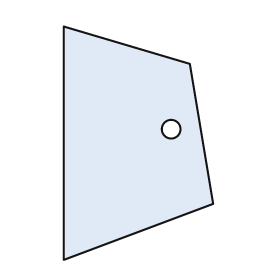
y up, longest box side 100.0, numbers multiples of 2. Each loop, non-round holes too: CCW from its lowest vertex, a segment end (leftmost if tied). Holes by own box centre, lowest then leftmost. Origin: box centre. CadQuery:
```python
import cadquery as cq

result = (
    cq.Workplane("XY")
    .moveTo(-32.0, -50.0)
    .lineTo(32.0, -26.0)
    .lineTo(22.0, 34.0)
    .lineTo(-32.0, 50.0)
    .close()
    .moveTo(14.0, 6.0)
    .circle(4.0)
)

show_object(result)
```